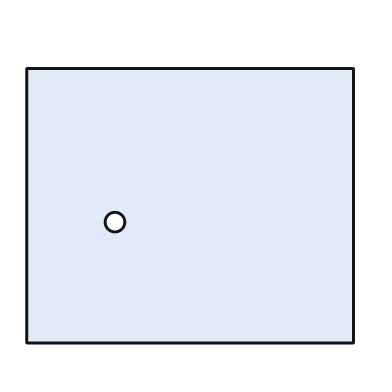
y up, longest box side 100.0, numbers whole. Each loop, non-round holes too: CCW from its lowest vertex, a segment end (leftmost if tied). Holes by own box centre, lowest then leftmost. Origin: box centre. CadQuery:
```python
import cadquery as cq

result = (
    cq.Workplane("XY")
    .moveTo(-50.0, -42.0)
    .lineTo(50.0, -42.0)
    .lineTo(50.0, 42.0)
    .lineTo(-50.0, 42.0)
    .close()
    .moveTo(-23.0, -5.0)
    .circle(3.0)
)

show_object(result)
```